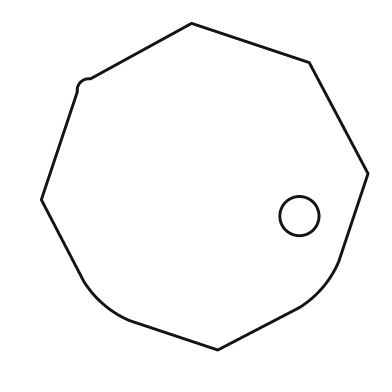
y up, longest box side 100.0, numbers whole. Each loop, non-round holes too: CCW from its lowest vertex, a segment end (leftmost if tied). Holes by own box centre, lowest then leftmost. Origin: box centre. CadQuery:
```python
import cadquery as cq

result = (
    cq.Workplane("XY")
    .moveTo(4.0, -50.0)
    .lineTo(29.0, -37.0)
    .threePointArc((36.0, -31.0), (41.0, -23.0))
    .lineTo(50.0, 4.0)
    .lineTo(32.0, 38.0)
    .lineTo(-4.0, 50.0)
    .lineTo(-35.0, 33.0)
    .threePointArc((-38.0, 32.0), (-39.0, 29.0))
    .lineTo(-50.0, -4.0)
    .lineTo(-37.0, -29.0)
    .threePointArc((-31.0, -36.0), (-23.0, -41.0))
    .close()
    .moveTo(29.0, -9.0)
    .circle(6.0)
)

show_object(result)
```